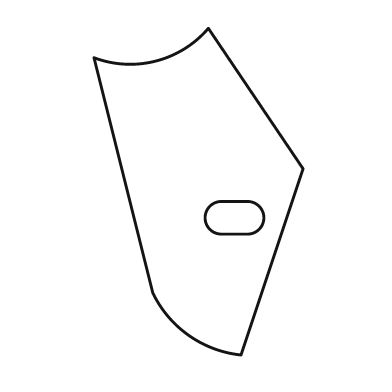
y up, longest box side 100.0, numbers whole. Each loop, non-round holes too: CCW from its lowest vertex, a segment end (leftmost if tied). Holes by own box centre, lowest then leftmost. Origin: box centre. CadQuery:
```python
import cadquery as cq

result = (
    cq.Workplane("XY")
    .moveTo(13.0, -50.0)
    .lineTo(32.0, 7.0)
    .lineTo(3.0, 50.0)
    .threePointArc((-13.0, 40.0), (-32.0, 41.0))
    .lineTo(-14.0, -31.0)
    .threePointArc((-3.0, -44.0), (13.0, -50.0))
    .close()
    .moveTo(7.0, -13.0)
    .lineTo(15.0, -13.0)
    .threePointArc((20.0, -8.0), (15.0, -3.0))
    .lineTo(7.0, -3.0)
    .threePointArc((2.0, -8.0), (7.0, -13.0))
    .close()
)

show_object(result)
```